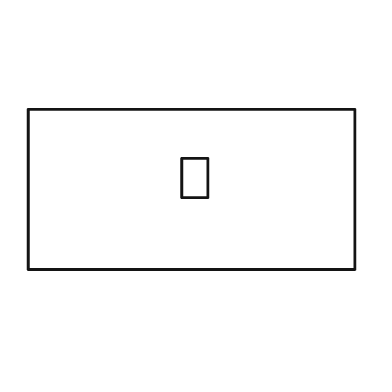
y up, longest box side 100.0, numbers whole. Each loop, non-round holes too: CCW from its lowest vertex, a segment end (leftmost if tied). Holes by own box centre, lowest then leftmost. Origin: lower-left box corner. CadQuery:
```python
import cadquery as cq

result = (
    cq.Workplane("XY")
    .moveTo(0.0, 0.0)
    .lineTo(100.0, 0.0)
    .lineTo(100.0, 49.0)
    .lineTo(0.0, 49.0)
    .close()
    .moveTo(47.0, 22.0)
    .lineTo(55.0, 22.0)
    .lineTo(55.0, 34.0)
    .lineTo(47.0, 34.0)
    .close()
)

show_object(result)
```